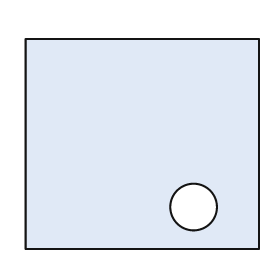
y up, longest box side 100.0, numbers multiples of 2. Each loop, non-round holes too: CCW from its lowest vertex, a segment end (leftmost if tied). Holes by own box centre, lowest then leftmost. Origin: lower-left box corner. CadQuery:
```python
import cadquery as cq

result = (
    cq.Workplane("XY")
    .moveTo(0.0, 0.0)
    .lineTo(100.0, 0.0)
    .lineTo(100.0, 90.0)
    .lineTo(0.0, 90.0)
    .close()
    .moveTo(72.0, 18.0)
    .circle(10.0)
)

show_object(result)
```